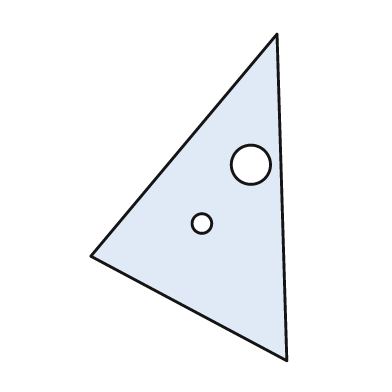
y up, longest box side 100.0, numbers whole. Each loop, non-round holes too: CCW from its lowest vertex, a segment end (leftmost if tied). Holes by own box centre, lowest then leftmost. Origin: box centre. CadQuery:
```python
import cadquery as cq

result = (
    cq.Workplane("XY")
    .moveTo(30.0, -50.0)
    .lineTo(27.0, 50.0)
    .lineTo(-30.0, -18.0)
    .close()
    .moveTo(4.0, -8.0)
    .circle(3.0)
    .moveTo(19.0, 10.0)
    .circle(6.0)
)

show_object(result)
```